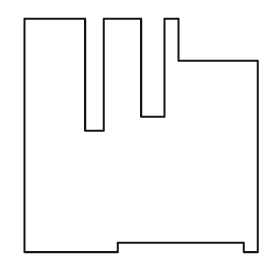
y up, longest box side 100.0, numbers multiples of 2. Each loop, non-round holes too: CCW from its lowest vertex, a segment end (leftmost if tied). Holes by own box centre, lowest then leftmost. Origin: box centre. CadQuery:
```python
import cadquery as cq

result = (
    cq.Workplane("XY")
    .moveTo(-50.0, -50.0)
    .lineTo(-10.0, -50.0)
    .lineTo(-10.0, -46.0)
    .lineTo(44.0, -46.0)
    .lineTo(44.0, -50.0)
    .lineTo(50.0, -50.0)
    .lineTo(50.0, 32.0)
    .lineTo(16.0, 32.0)
    .lineTo(16.0, 50.0)
    .lineTo(10.0, 50.0)
    .lineTo(10.0, 8.0)
    .lineTo(0.0, 8.0)
    .lineTo(0.0, 50.0)
    .lineTo(-16.0, 50.0)
    .lineTo(-16.0, 2.0)
    .lineTo(-24.0, 2.0)
    .lineTo(-24.0, 50.0)
    .lineTo(-50.0, 50.0)
    .close()
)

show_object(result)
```